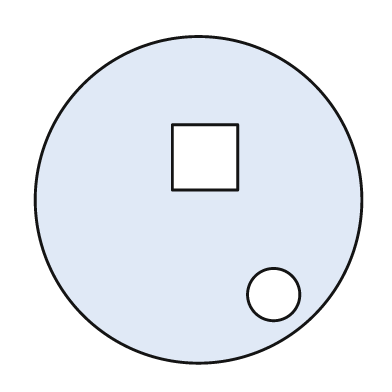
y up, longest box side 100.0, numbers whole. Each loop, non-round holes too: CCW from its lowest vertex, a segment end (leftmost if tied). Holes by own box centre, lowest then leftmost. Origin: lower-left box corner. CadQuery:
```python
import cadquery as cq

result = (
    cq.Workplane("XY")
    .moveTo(50.0, 50.0)
    .circle(50.0)
    .moveTo(73.0, 21.0)
    .circle(8.0)
    .moveTo(42.0, 53.0)
    .lineTo(62.0, 53.0)
    .lineTo(62.0, 73.0)
    .lineTo(42.0, 73.0)
    .close()
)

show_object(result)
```